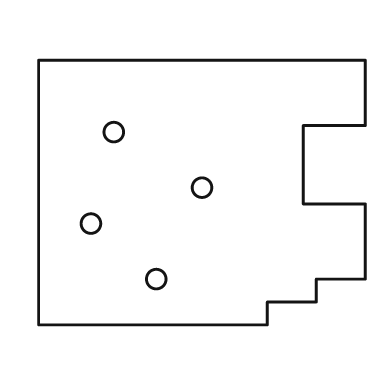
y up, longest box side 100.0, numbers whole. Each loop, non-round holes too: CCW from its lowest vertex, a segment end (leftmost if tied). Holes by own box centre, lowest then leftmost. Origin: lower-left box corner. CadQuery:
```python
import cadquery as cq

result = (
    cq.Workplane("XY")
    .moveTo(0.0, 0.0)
    .lineTo(70.0, 0.0)
    .lineTo(70.0, 7.0)
    .lineTo(85.0, 7.0)
    .lineTo(85.0, 14.0)
    .lineTo(100.0, 14.0)
    .lineTo(100.0, 37.0)
    .lineTo(81.0, 37.0)
    .lineTo(81.0, 61.0)
    .lineTo(100.0, 61.0)
    .lineTo(100.0, 81.0)
    .lineTo(0.0, 81.0)
    .close()
    .moveTo(36.0, 14.0)
    .circle(3.0)
    .moveTo(16.0, 31.0)
    .circle(3.0)
    .moveTo(50.0, 42.0)
    .circle(3.0)
    .moveTo(23.0, 59.0)
    .circle(3.0)
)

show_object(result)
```